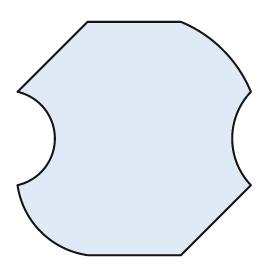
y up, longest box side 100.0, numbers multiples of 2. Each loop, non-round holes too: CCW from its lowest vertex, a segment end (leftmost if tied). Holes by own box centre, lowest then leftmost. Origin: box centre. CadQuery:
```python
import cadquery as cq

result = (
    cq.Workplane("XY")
    .moveTo(-20.0, -50.0)
    .lineTo(20.0, -50.0)
    .lineTo(50.0, -20.0)
    .threePointArc((42.0, 0.0), (50.0, 20.0))
    .threePointArc((38.0, 38.0), (20.0, 50.0))
    .lineTo(-20.0, 50.0)
    .lineTo(-50.0, 20.0)
    .threePointArc((-34.0, 0.0), (-50.0, -20.0))
    .threePointArc((-40.0, -40.0), (-20.0, -50.0))
    .close()
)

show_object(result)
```